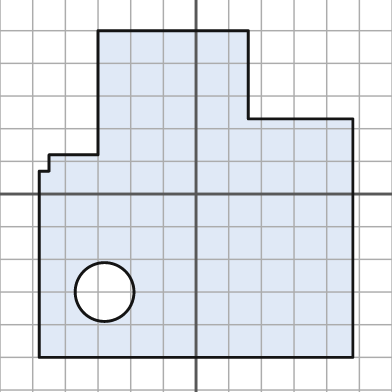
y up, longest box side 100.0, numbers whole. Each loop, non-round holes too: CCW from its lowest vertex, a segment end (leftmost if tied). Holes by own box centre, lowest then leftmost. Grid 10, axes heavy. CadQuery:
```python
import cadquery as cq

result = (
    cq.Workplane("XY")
    .moveTo(-48.0, -50.0)
    .lineTo(48.0, -50.0)
    .lineTo(48.0, 23.0)
    .lineTo(16.0, 23.0)
    .lineTo(16.0, 50.0)
    .lineTo(-30.0, 50.0)
    .lineTo(-30.0, 12.0)
    .lineTo(-45.0, 12.0)
    .lineTo(-45.0, 7.0)
    .lineTo(-48.0, 7.0)
    .close()
    .moveTo(-28.0, -30.0)
    .circle(9.0)
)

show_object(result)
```